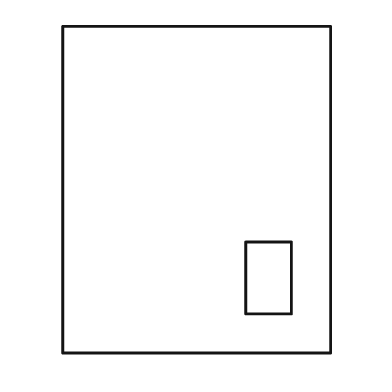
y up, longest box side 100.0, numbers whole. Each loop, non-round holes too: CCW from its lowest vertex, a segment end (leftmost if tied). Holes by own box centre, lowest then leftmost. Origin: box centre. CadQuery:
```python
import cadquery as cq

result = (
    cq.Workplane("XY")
    .moveTo(-41.0, -50.0)
    .lineTo(41.0, -50.0)
    .lineTo(41.0, 50.0)
    .lineTo(-41.0, 50.0)
    .close()
    .moveTo(15.0, -38.0)
    .lineTo(29.0, -38.0)
    .lineTo(29.0, -16.0)
    .lineTo(15.0, -16.0)
    .close()
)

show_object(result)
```